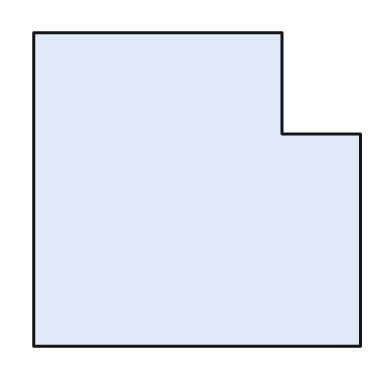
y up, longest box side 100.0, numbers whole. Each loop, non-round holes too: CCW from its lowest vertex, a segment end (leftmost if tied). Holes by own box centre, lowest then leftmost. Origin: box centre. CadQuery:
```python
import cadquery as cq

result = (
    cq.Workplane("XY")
    .moveTo(-50.0, -48.0)
    .lineTo(50.0, -48.0)
    .lineTo(50.0, 17.0)
    .lineTo(26.0, 17.0)
    .lineTo(26.0, 48.0)
    .lineTo(-50.0, 48.0)
    .close()
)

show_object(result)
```